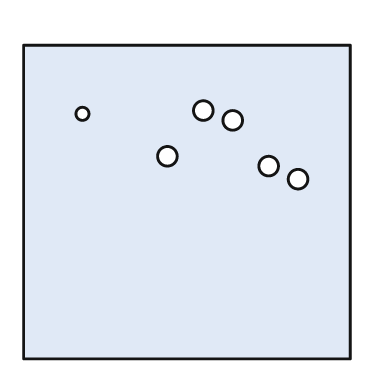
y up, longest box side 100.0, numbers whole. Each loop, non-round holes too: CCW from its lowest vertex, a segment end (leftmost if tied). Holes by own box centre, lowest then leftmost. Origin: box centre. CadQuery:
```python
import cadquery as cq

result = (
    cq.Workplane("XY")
    .moveTo(-50.0, -48.0)
    .lineTo(50.0, -48.0)
    .lineTo(50.0, 48.0)
    .lineTo(-50.0, 48.0)
    .close()
    .moveTo(34.0, 7.0)
    .circle(3.0)
    .moveTo(25.0, 11.0)
    .circle(3.0)
    .moveTo(-6.0, 14.0)
    .circle(3.0)
    .moveTo(14.0, 25.0)
    .circle(3.0)
    .moveTo(-32.0, 27.0)
    .circle(2.0)
    .moveTo(5.0, 28.0)
    .circle(3.0)
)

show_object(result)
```